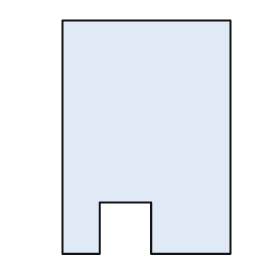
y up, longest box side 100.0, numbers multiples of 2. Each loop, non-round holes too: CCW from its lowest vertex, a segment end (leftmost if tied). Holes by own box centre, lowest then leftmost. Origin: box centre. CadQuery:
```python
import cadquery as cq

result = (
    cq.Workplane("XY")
    .moveTo(-36.0, -50.0)
    .lineTo(-20.0, -50.0)
    .lineTo(-20.0, -28.0)
    .lineTo(2.0, -28.0)
    .lineTo(2.0, -50.0)
    .lineTo(36.0, -50.0)
    .lineTo(36.0, 50.0)
    .lineTo(-36.0, 50.0)
    .close()
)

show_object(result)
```